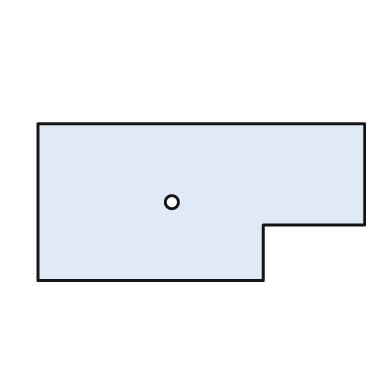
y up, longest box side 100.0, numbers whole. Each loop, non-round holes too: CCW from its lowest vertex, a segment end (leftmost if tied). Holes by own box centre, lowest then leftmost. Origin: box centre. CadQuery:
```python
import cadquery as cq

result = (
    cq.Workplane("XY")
    .moveTo(-50.0, -24.0)
    .lineTo(19.0, -24.0)
    .lineTo(19.0, -7.0)
    .lineTo(50.0, -7.0)
    .lineTo(50.0, 24.0)
    .lineTo(-50.0, 24.0)
    .close()
    .moveTo(-9.0, 0.0)
    .circle(2.0)
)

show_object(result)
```